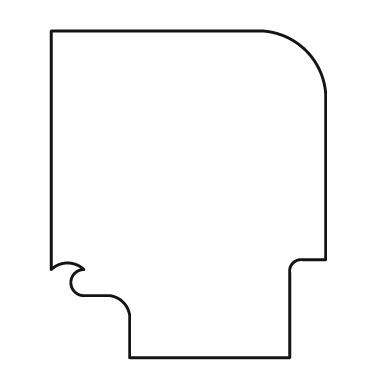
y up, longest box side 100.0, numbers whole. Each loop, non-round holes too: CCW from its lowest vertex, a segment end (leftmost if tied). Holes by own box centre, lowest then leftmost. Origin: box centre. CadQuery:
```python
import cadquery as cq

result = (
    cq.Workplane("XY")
    .moveTo(-18.0, -50.0)
    .lineTo(31.0, -50.0)
    .lineTo(31.0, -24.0)
    .threePointArc((32.0, -21.0), (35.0, -20.0))
    .lineTo(42.0, -20.0)
    .lineTo(42.0, 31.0)
    .threePointArc((36.0, 44.0), (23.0, 50.0))
    .lineTo(-42.0, 50.0)
    .lineTo(-42.0, -23.0)
    .threePointArc((-37.0, -21.0), (-32.0, -23.0))
    .threePointArc((-36.0, -27.0), (-32.0, -31.0))
    .lineTo(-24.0, -31.0)
    .threePointArc((-20.0, -33.0), (-18.0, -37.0))
    .close()
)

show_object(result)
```